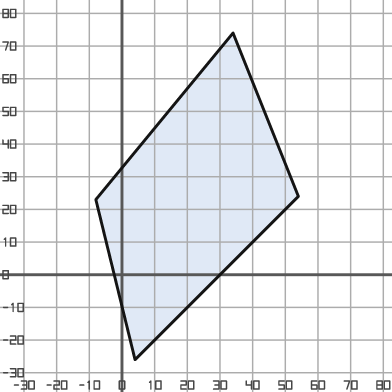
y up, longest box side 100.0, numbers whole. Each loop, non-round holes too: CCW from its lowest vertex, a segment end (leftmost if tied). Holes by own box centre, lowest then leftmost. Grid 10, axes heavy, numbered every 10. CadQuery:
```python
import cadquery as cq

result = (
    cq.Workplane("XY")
    .moveTo(4.0, -26.0)
    .lineTo(54.0, 24.0)
    .lineTo(34.0, 74.0)
    .lineTo(-8.0, 23.0)
    .close()
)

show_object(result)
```